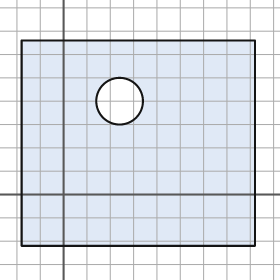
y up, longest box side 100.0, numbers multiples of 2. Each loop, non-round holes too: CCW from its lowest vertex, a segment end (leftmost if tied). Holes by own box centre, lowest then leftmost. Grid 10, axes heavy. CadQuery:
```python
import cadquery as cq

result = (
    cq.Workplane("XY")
    .moveTo(-18.0, -22.0)
    .lineTo(82.0, -22.0)
    .lineTo(82.0, 66.0)
    .lineTo(-18.0, 66.0)
    .close()
    .moveTo(24.0, 40.0)
    .circle(10.0)
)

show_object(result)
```